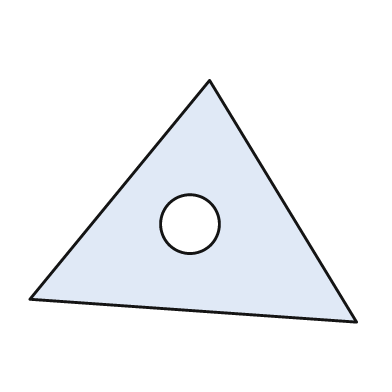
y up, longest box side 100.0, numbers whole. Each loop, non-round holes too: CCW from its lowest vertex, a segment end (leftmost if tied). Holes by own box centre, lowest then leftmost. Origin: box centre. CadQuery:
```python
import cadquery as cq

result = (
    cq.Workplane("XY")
    .moveTo(50.0, -37.0)
    .lineTo(5.0, 37.0)
    .lineTo(-50.0, -30.0)
    .close()
    .moveTo(-1.0, -7.0)
    .circle(9.0)
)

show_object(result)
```